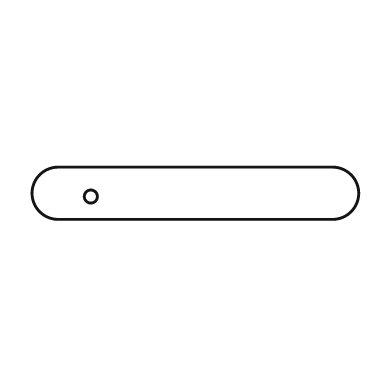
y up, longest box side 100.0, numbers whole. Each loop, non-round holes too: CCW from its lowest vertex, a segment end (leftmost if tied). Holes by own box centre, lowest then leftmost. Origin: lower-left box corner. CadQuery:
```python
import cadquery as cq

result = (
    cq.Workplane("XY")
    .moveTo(8.0, 0.0)
    .lineTo(92.0, 0.0)
    .threePointArc((100.0, 8.0), (92.0, 16.0))
    .lineTo(8.0, 16.0)
    .threePointArc((0.0, 8.0), (8.0, 0.0))
    .close()
    .moveTo(18.0, 7.0)
    .circle(2.0)
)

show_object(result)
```